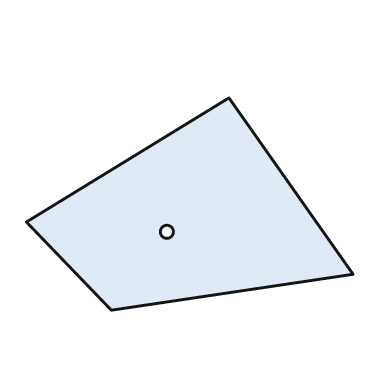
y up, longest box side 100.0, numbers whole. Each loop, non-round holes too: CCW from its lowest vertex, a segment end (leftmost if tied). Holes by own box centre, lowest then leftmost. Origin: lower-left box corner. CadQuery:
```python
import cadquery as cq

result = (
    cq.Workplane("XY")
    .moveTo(26.0, 0.0)
    .lineTo(100.0, 11.0)
    .lineTo(62.0, 65.0)
    .lineTo(0.0, 27.0)
    .close()
    .moveTo(43.0, 24.0)
    .circle(2.0)
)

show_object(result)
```